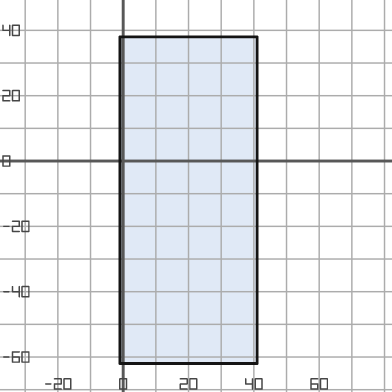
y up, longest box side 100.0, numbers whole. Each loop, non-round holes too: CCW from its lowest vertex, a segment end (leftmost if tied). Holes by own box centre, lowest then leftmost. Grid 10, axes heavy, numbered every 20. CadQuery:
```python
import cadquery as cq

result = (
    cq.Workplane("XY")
    .moveTo(-1.0, -62.0)
    .lineTo(41.0, -62.0)
    .lineTo(41.0, 38.0)
    .lineTo(-1.0, 38.0)
    .close()
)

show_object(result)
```